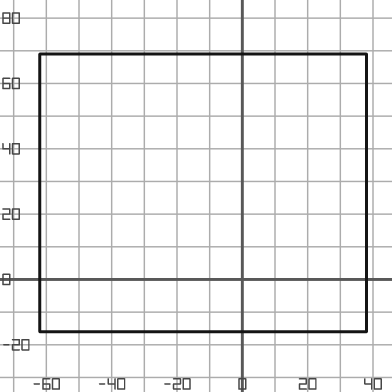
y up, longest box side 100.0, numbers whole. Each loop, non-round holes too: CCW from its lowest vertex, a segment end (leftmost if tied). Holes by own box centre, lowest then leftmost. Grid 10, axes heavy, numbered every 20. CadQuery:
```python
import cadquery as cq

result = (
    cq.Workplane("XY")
    .moveTo(-62.0, -16.0)
    .lineTo(38.0, -16.0)
    .lineTo(38.0, 69.0)
    .lineTo(-62.0, 69.0)
    .close()
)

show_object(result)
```